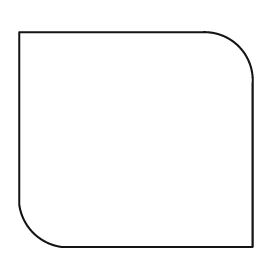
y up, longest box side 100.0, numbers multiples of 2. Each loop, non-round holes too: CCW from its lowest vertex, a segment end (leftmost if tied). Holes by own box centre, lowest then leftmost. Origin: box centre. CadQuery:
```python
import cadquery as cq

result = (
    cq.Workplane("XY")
    .moveTo(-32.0, -46.0)
    .lineTo(50.0, -46.0)
    .lineTo(50.0, 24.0)
    .threePointArc((44.0, 40.0), (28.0, 46.0))
    .lineTo(-50.0, 46.0)
    .lineTo(-50.0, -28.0)
    .threePointArc((-44.0, -40.0), (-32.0, -46.0))
    .close()
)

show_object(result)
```